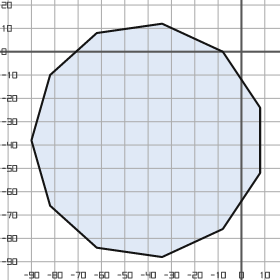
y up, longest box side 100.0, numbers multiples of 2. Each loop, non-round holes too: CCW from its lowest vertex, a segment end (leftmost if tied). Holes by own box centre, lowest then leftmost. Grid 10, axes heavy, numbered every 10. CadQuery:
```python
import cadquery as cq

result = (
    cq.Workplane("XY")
    .moveTo(-34.0, -88.0)
    .lineTo(-8.0, -76.0)
    .lineTo(8.0, -52.0)
    .lineTo(8.0, -24.0)
    .lineTo(-8.0, 0.0)
    .lineTo(-34.0, 12.0)
    .lineTo(-62.0, 8.0)
    .lineTo(-82.0, -10.0)
    .lineTo(-90.0, -38.0)
    .lineTo(-82.0, -66.0)
    .lineTo(-62.0, -84.0)
    .close()
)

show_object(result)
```